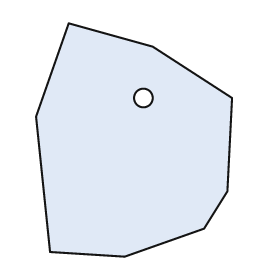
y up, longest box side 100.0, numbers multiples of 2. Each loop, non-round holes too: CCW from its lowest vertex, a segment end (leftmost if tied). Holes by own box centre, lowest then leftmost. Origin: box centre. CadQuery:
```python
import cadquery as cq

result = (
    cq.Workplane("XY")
    .moveTo(-4.0, -50.0)
    .lineTo(30.0, -38.0)
    .lineTo(40.0, -22.0)
    .lineTo(42.0, 18.0)
    .lineTo(8.0, 40.0)
    .lineTo(-28.0, 50.0)
    .lineTo(-42.0, 10.0)
    .lineTo(-36.0, -48.0)
    .close()
    .moveTo(4.0, 18.0)
    .circle(4.0)
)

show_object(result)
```